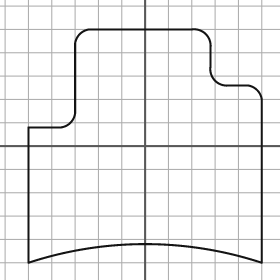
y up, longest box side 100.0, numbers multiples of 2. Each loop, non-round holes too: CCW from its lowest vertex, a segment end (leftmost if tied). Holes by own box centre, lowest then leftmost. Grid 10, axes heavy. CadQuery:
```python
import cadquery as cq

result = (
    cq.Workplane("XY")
    .moveTo(-50.0, -50.0)
    .threePointArc((0.0, -42.0), (50.0, -50.0))
    .lineTo(50.0, 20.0)
    .threePointArc((48.0, 24.0), (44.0, 26.0))
    .lineTo(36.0, 26.0)
    .threePointArc((30.0, 28.0), (28.0, 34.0))
    .lineTo(28.0, 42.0)
    .threePointArc((26.0, 48.0), (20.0, 50.0))
    .lineTo(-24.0, 50.0)
    .threePointArc((-28.0, 48.0), (-30.0, 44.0))
    .lineTo(-30.0, 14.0)
    .threePointArc((-32.0, 10.0), (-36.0, 8.0))
    .lineTo(-50.0, 8.0)
    .close()
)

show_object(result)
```